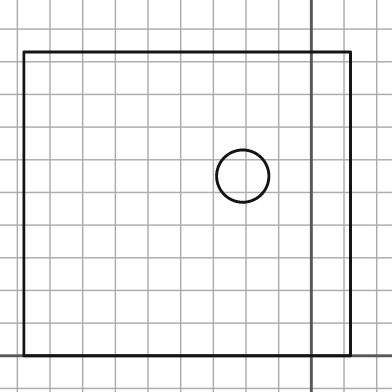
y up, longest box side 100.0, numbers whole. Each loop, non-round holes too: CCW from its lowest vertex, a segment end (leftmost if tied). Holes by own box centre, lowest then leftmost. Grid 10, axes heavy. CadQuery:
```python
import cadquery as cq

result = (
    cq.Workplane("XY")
    .moveTo(-88.0, 0.0)
    .lineTo(12.0, 0.0)
    .lineTo(12.0, 93.0)
    .lineTo(-88.0, 93.0)
    .close()
    .moveTo(-21.0, 55.0)
    .circle(8.0)
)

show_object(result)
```